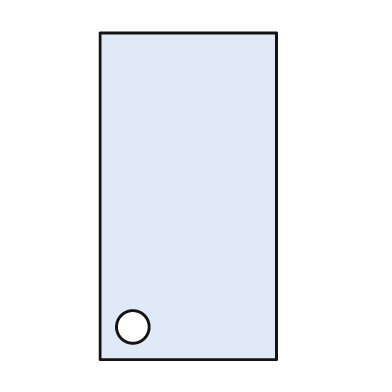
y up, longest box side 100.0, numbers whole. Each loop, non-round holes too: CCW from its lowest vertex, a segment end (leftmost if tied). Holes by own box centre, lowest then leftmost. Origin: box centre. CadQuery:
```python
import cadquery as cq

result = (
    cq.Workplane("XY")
    .moveTo(-27.0, -50.0)
    .lineTo(27.0, -50.0)
    .lineTo(27.0, 50.0)
    .lineTo(-27.0, 50.0)
    .close()
    .moveTo(-17.0, -40.0)
    .circle(5.0)
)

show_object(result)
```